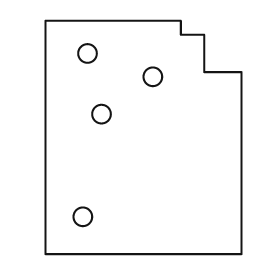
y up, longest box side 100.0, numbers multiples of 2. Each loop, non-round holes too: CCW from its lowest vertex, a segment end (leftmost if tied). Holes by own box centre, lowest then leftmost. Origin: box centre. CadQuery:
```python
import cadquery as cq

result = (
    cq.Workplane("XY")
    .moveTo(-42.0, -50.0)
    .lineTo(42.0, -50.0)
    .lineTo(42.0, 28.0)
    .lineTo(26.0, 28.0)
    .lineTo(26.0, 44.0)
    .lineTo(16.0, 44.0)
    .lineTo(16.0, 50.0)
    .lineTo(-42.0, 50.0)
    .close()
    .moveTo(-26.0, -34.0)
    .circle(4.0)
    .moveTo(-18.0, 10.0)
    .circle(4.0)
    .moveTo(4.0, 26.0)
    .circle(4.0)
    .moveTo(-24.0, 36.0)
    .circle(4.0)
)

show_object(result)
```